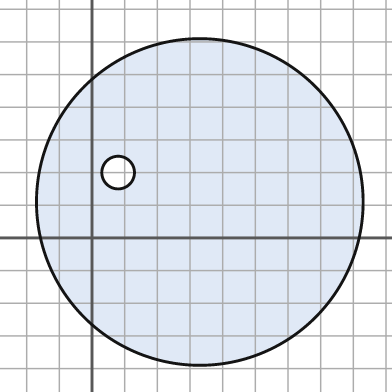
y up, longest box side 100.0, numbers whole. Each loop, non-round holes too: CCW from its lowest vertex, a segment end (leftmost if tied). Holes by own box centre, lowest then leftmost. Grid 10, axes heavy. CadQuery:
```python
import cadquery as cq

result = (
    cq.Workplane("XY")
    .moveTo(33.0, 11.0)
    .circle(50.0)
    .moveTo(8.0, 20.0)
    .circle(5.0)
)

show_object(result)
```